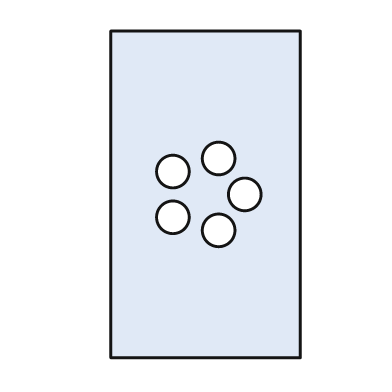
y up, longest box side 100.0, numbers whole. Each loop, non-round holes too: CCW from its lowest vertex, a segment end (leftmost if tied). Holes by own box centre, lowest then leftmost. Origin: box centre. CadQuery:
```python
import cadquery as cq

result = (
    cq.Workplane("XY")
    .moveTo(-29.0, -50.0)
    .lineTo(29.0, -50.0)
    .lineTo(29.0, 50.0)
    .lineTo(-29.0, 50.0)
    .close()
    .moveTo(4.0, -11.0)
    .circle(5.0)
    .moveTo(-10.0, -7.0)
    .circle(5.0)
    .moveTo(12.0, 0.0)
    .circle(5.0)
    .moveTo(-10.0, 7.0)
    .circle(5.0)
    .moveTo(4.0, 11.0)
    .circle(5.0)
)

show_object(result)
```